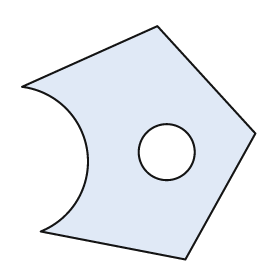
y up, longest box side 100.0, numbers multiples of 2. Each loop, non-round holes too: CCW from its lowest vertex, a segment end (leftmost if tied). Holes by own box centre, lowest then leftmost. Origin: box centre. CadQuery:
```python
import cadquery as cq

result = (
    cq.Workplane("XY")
    .moveTo(20.0, -50.0)
    .lineTo(50.0, 4.0)
    .lineTo(8.0, 50.0)
    .lineTo(-50.0, 24.0)
    .threePointArc((-22.0, -4.0), (-42.0, -38.0))
    .close()
    .moveTo(12.0, -4.0)
    .circle(12.0)
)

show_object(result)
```